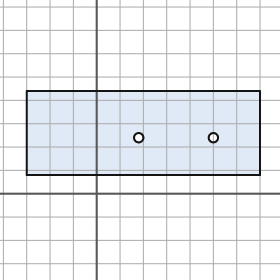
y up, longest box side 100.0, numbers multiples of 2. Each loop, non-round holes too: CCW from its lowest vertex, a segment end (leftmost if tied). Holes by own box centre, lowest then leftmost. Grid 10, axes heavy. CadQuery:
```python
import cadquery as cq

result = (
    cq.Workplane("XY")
    .moveTo(-30.0, 8.0)
    .lineTo(70.0, 8.0)
    .lineTo(70.0, 44.0)
    .lineTo(-30.0, 44.0)
    .close()
    .moveTo(18.0, 24.0)
    .circle(2.0)
    .moveTo(50.0, 24.0)
    .circle(2.0)
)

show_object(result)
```